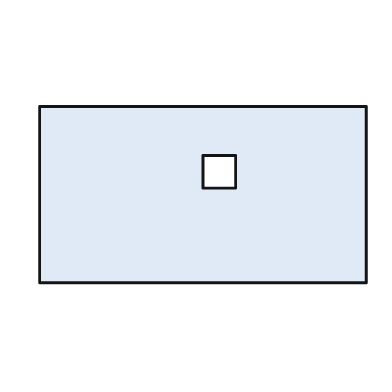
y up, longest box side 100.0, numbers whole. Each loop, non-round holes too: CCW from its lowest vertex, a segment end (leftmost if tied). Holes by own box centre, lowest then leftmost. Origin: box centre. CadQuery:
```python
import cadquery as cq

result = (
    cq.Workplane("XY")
    .moveTo(-50.0, -27.0)
    .lineTo(50.0, -27.0)
    .lineTo(50.0, 27.0)
    .lineTo(-50.0, 27.0)
    .close()
    .moveTo(0.0, 2.0)
    .lineTo(10.0, 2.0)
    .lineTo(10.0, 12.0)
    .lineTo(0.0, 12.0)
    .close()
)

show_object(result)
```